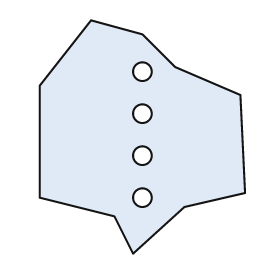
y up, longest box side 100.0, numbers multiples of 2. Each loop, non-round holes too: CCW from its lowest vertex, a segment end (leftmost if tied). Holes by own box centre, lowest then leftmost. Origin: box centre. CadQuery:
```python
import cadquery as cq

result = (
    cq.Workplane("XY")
    .moveTo(-4.0, -50.0)
    .lineTo(18.0, -30.0)
    .lineTo(44.0, -24.0)
    .lineTo(42.0, 18.0)
    .lineTo(14.0, 30.0)
    .lineTo(0.0, 44.0)
    .lineTo(-22.0, 50.0)
    .lineTo(-44.0, 22.0)
    .lineTo(-44.0, -26.0)
    .lineTo(-12.0, -34.0)
    .close()
    .moveTo(0.0, -26.0)
    .circle(4.0)
    .moveTo(0.0, -8.0)
    .circle(4.0)
    .moveTo(0.0, 10.0)
    .circle(4.0)
    .moveTo(0.0, 28.0)
    .circle(4.0)
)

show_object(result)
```